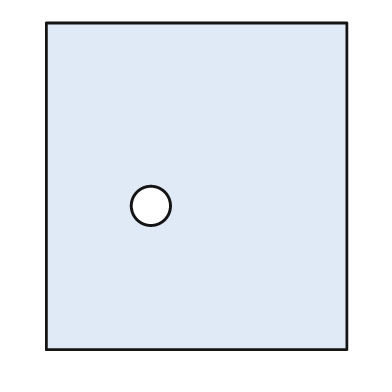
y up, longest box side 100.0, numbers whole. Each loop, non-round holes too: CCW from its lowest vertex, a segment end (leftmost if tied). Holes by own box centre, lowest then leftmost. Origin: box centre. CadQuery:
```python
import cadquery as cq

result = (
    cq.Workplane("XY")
    .moveTo(-46.0, -50.0)
    .lineTo(46.0, -50.0)
    .lineTo(46.0, 50.0)
    .lineTo(-46.0, 50.0)
    .close()
    .moveTo(-14.0, -6.0)
    .circle(6.0)
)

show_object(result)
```